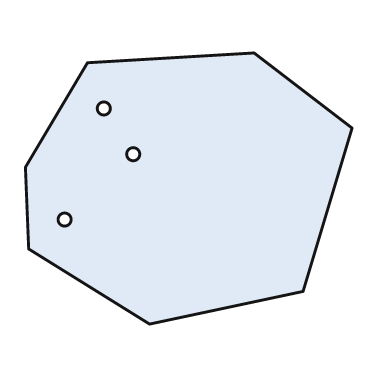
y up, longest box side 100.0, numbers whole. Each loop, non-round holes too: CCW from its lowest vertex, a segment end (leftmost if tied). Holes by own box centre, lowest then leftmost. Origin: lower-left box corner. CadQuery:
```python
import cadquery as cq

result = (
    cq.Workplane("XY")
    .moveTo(38.0, 0.0)
    .lineTo(85.0, 10.0)
    .lineTo(100.0, 60.0)
    .lineTo(70.0, 83.0)
    .lineTo(19.0, 80.0)
    .lineTo(0.0, 48.0)
    .lineTo(1.0, 23.0)
    .close()
    .moveTo(12.0, 32.0)
    .circle(2.0)
    .moveTo(33.0, 52.0)
    .circle(2.0)
    .moveTo(24.0, 66.0)
    .circle(2.0)
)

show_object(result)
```